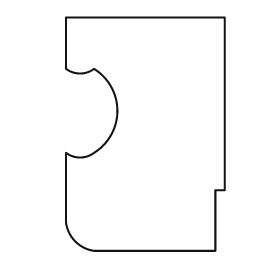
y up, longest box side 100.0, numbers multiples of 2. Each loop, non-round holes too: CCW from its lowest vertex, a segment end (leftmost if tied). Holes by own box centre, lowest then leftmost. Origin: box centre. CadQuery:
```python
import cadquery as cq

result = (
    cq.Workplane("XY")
    .moveTo(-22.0, -50.0)
    .lineTo(30.0, -50.0)
    .lineTo(30.0, -24.0)
    .lineTo(34.0, -24.0)
    .lineTo(34.0, 50.0)
    .lineTo(-34.0, 50.0)
    .lineTo(-34.0, 28.0)
    .threePointArc((-28.0, 26.0), (-22.0, 28.0))
    .threePointArc((-12.0, 10.0), (-22.0, -8.0))
    .threePointArc((-28.0, -10.0), (-34.0, -8.0))
    .lineTo(-34.0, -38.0)
    .threePointArc((-30.0, -46.0), (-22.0, -50.0))
    .close()
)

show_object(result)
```